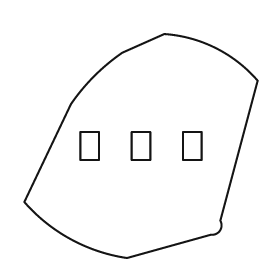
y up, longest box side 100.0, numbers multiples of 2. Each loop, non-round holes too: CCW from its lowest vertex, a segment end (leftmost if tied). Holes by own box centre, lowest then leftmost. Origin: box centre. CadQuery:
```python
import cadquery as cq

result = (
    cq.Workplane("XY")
    .moveTo(-6.0, -48.0)
    .lineTo(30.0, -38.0)
    .threePointArc((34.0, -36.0), (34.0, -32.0))
    .lineTo(50.0, 28.0)
    .threePointArc((32.0, 42.0), (10.0, 48.0))
    .lineTo(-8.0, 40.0)
    .threePointArc((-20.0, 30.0), (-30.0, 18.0))
    .lineTo(-50.0, -24.0)
    .threePointArc((-30.0, -40.0), (-6.0, -48.0))
    .close()
    .moveTo(-26.0, -6.0)
    .lineTo(-18.0, -6.0)
    .lineTo(-18.0, 6.0)
    .lineTo(-26.0, 6.0)
    .close()
    .moveTo(-4.0, -6.0)
    .lineTo(4.0, -6.0)
    .lineTo(4.0, 6.0)
    .lineTo(-4.0, 6.0)
    .close()
    .moveTo(18.0, -6.0)
    .lineTo(26.0, -6.0)
    .lineTo(26.0, 6.0)
    .lineTo(18.0, 6.0)
    .close()
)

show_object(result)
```